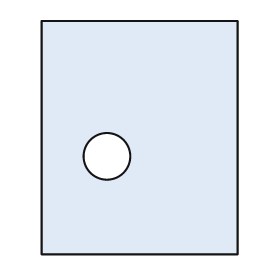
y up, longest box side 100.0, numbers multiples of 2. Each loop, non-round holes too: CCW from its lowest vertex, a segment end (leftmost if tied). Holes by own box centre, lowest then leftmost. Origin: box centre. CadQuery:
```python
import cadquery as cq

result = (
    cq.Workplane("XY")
    .moveTo(-42.0, -50.0)
    .lineTo(42.0, -50.0)
    .lineTo(42.0, 50.0)
    .lineTo(-42.0, 50.0)
    .close()
    .moveTo(-14.0, -8.0)
    .circle(10.0)
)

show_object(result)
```